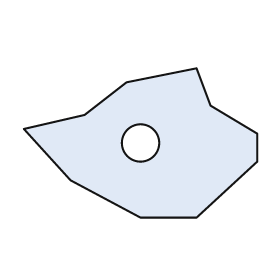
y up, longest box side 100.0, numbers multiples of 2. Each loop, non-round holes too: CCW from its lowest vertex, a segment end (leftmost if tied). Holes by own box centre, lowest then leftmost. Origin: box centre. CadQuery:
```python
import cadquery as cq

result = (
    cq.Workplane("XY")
    .moveTo(0.0, -32.0)
    .lineTo(24.0, -32.0)
    .lineTo(50.0, -8.0)
    .lineTo(50.0, 4.0)
    .lineTo(30.0, 16.0)
    .lineTo(24.0, 32.0)
    .lineTo(-6.0, 26.0)
    .lineTo(-24.0, 12.0)
    .lineTo(-50.0, 6.0)
    .lineTo(-30.0, -16.0)
    .close()
    .moveTo(0.0, 0.0)
    .circle(8.0)
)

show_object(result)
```